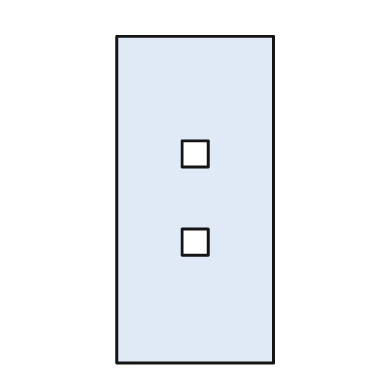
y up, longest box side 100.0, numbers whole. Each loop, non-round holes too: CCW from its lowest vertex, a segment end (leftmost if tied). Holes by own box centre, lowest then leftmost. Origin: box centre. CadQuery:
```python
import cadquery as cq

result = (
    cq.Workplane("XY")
    .moveTo(-24.0, -50.0)
    .lineTo(24.0, -50.0)
    .lineTo(24.0, 50.0)
    .lineTo(-24.0, 50.0)
    .close()
    .moveTo(-4.0, -17.0)
    .lineTo(4.0, -17.0)
    .lineTo(4.0, -9.0)
    .lineTo(-4.0, -9.0)
    .close()
    .moveTo(-4.0, 10.0)
    .lineTo(4.0, 10.0)
    .lineTo(4.0, 18.0)
    .lineTo(-4.0, 18.0)
    .close()
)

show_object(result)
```